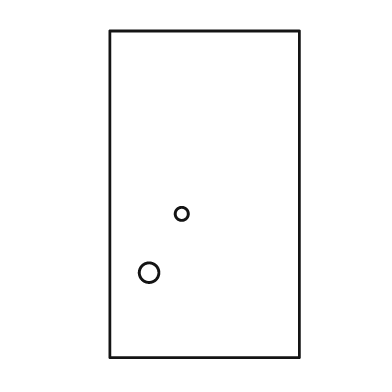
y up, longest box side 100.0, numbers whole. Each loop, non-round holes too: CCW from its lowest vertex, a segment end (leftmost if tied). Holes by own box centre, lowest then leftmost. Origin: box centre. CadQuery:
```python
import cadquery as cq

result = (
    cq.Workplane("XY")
    .moveTo(-29.0, -50.0)
    .lineTo(29.0, -50.0)
    .lineTo(29.0, 50.0)
    .lineTo(-29.0, 50.0)
    .close()
    .moveTo(-17.0, -24.0)
    .circle(3.0)
    .moveTo(-7.0, -6.0)
    .circle(2.0)
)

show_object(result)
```